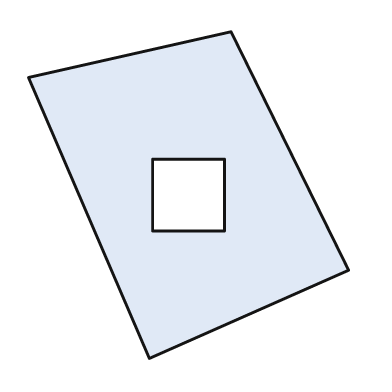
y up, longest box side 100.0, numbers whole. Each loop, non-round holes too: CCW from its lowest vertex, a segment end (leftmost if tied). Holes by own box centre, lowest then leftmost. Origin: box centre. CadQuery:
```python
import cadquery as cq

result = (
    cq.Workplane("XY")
    .moveTo(-12.0, -50.0)
    .lineTo(49.0, -23.0)
    .lineTo(13.0, 50.0)
    .lineTo(-49.0, 36.0)
    .close()
    .moveTo(-11.0, -11.0)
    .lineTo(11.0, -11.0)
    .lineTo(11.0, 11.0)
    .lineTo(-11.0, 11.0)
    .close()
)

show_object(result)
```